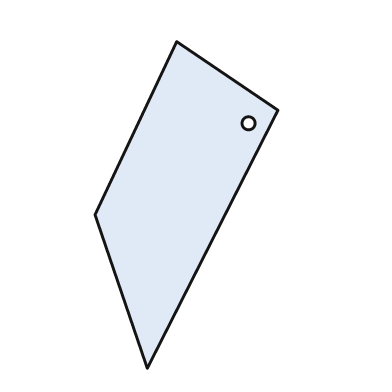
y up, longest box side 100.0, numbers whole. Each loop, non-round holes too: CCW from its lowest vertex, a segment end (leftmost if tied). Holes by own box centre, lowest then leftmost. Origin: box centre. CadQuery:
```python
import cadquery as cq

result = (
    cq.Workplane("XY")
    .moveTo(-12.0, -50.0)
    .lineTo(28.0, 29.0)
    .lineTo(-3.0, 50.0)
    .lineTo(-28.0, -3.0)
    .close()
    .moveTo(19.0, 25.0)
    .circle(2.0)
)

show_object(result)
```